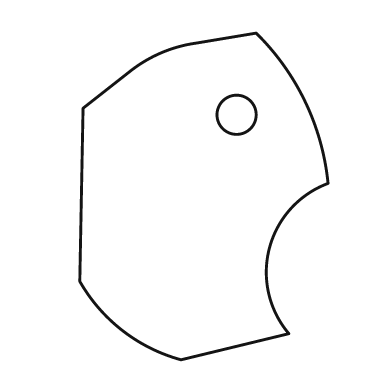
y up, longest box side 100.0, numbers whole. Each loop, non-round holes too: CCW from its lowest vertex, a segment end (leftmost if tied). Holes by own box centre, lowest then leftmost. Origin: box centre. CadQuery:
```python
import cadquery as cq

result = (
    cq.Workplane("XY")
    .moveTo(-7.0, -50.0)
    .lineTo(26.0, -42.0)
    .threePointArc((20.0, -16.0), (38.0, 4.0))
    .threePointArc((31.0, 29.0), (16.0, 50.0))
    .lineTo(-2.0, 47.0)
    .threePointArc((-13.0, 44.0), (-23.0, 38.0))
    .lineTo(-37.0, 27.0)
    .lineTo(-38.0, -26.0)
    .threePointArc((-25.0, -41.0), (-7.0, -50.0))
    .close()
    .moveTo(10.0, 25.0)
    .circle(6.0)
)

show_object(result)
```